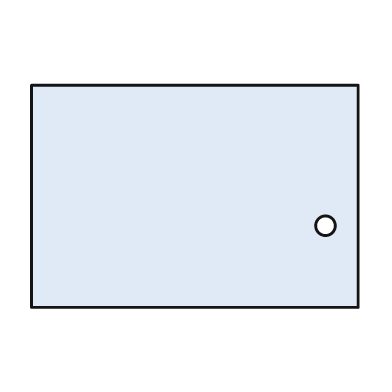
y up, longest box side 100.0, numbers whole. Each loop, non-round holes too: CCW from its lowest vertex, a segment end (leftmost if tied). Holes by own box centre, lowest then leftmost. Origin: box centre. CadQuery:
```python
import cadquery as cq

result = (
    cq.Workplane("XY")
    .moveTo(-50.0, -34.0)
    .lineTo(50.0, -34.0)
    .lineTo(50.0, 34.0)
    .lineTo(-50.0, 34.0)
    .close()
    .moveTo(40.0, -9.0)
    .circle(3.0)
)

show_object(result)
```